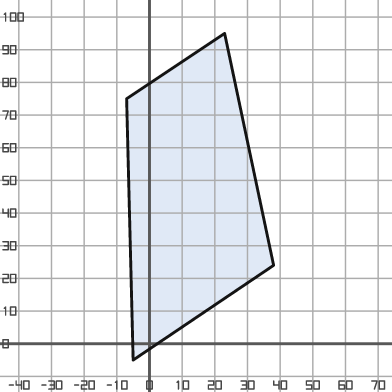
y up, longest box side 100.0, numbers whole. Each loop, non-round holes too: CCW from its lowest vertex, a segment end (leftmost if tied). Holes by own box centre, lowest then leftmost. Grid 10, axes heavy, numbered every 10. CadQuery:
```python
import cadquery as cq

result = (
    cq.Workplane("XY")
    .moveTo(-5.0, -5.0)
    .lineTo(38.0, 24.0)
    .lineTo(23.0, 95.0)
    .lineTo(-7.0, 75.0)
    .close()
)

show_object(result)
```